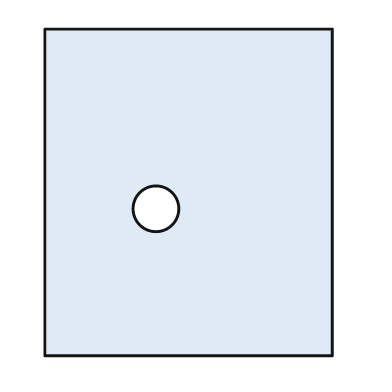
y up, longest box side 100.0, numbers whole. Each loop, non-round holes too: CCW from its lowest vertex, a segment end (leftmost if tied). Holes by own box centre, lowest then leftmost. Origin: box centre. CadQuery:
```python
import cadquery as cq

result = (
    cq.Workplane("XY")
    .moveTo(-44.0, -50.0)
    .lineTo(44.0, -50.0)
    .lineTo(44.0, 50.0)
    .lineTo(-44.0, 50.0)
    .close()
    .moveTo(-10.0, -5.0)
    .circle(7.0)
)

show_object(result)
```